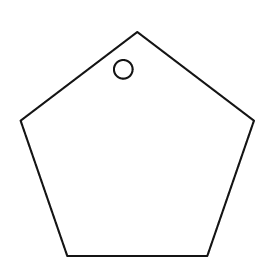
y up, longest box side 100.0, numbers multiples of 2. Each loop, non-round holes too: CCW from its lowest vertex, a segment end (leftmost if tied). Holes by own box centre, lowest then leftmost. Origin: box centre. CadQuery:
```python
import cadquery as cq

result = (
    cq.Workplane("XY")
    .moveTo(-30.0, -48.0)
    .lineTo(30.0, -48.0)
    .lineTo(50.0, 10.0)
    .lineTo(0.0, 48.0)
    .lineTo(-50.0, 10.0)
    .close()
    .moveTo(-6.0, 32.0)
    .circle(4.0)
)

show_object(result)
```